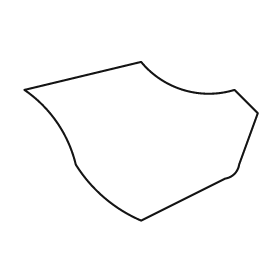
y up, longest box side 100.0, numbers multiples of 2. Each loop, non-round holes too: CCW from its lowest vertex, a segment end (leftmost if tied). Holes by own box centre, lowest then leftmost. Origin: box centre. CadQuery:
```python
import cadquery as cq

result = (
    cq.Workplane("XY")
    .moveTo(0.0, -34.0)
    .lineTo(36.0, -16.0)
    .threePointArc((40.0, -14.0), (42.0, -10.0))
    .lineTo(50.0, 12.0)
    .lineTo(40.0, 22.0)
    .threePointArc((18.0, 22.0), (0.0, 34.0))
    .lineTo(-50.0, 22.0)
    .threePointArc((-36.0, 8.0), (-28.0, -10.0))
    .threePointArc((-16.0, -24.0), (0.0, -34.0))
    .close()
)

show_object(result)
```